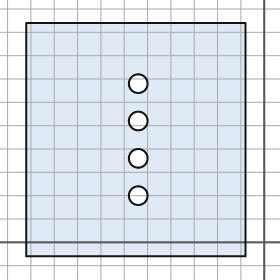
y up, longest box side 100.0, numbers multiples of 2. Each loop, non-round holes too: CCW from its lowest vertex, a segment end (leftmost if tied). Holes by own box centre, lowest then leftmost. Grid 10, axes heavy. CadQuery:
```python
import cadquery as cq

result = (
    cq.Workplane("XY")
    .moveTo(-102.0, -6.0)
    .lineTo(-8.0, -6.0)
    .lineTo(-8.0, 94.0)
    .lineTo(-102.0, 94.0)
    .close()
    .moveTo(-54.0, 20.0)
    .circle(4.0)
    .moveTo(-54.0, 36.0)
    .circle(4.0)
    .moveTo(-54.0, 52.0)
    .circle(4.0)
    .moveTo(-54.0, 68.0)
    .circle(4.0)
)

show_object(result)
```